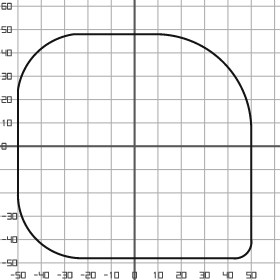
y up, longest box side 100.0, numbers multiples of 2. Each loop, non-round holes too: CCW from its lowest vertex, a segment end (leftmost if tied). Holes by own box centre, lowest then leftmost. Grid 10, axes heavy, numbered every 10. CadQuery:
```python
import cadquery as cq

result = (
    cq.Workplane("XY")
    .moveTo(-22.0, -48.0)
    .lineTo(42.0, -48.0)
    .threePointArc((48.0, -46.0), (50.0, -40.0))
    .lineTo(50.0, 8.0)
    .threePointArc((38.0, 36.0), (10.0, 48.0))
    .lineTo(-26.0, 48.0)
    .threePointArc((-42.0, 40.0), (-50.0, 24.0))
    .lineTo(-50.0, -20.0)
    .threePointArc((-42.0, -40.0), (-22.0, -48.0))
    .close()
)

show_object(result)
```